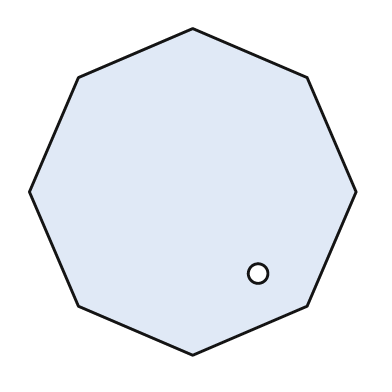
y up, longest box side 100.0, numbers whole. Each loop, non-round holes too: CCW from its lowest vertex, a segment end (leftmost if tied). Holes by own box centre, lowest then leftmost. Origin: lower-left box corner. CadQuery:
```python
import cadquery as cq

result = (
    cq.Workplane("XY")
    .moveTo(50.0, 0.0)
    .lineTo(85.0, 15.0)
    .lineTo(100.0, 50.0)
    .lineTo(85.0, 85.0)
    .lineTo(50.0, 100.0)
    .lineTo(15.0, 85.0)
    .lineTo(0.0, 50.0)
    .lineTo(15.0, 15.0)
    .close()
    .moveTo(70.0, 25.0)
    .circle(3.0)
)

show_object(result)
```